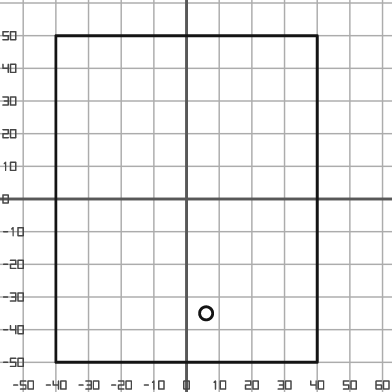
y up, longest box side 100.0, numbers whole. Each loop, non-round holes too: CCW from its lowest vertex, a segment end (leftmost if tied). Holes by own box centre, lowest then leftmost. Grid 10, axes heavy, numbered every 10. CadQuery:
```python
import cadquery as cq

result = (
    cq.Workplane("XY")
    .moveTo(-40.0, -50.0)
    .lineTo(40.0, -50.0)
    .lineTo(40.0, 50.0)
    .lineTo(-40.0, 50.0)
    .close()
    .moveTo(6.0, -35.0)
    .circle(2.0)
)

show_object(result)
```